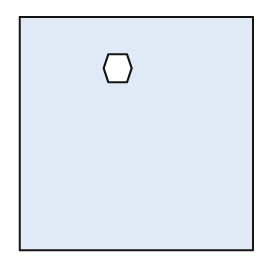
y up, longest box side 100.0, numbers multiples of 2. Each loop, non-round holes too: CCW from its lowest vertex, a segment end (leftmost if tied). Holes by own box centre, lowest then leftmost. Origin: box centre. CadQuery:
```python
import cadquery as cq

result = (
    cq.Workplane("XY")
    .moveTo(-50.0, -50.0)
    .lineTo(50.0, -50.0)
    .lineTo(50.0, 50.0)
    .lineTo(-50.0, 50.0)
    .close()
    .moveTo(-12.0, 22.0)
    .lineTo(-4.0, 22.0)
    .lineTo(-2.0, 28.0)
    .lineTo(-4.0, 34.0)
    .lineTo(-12.0, 34.0)
    .lineTo(-14.0, 28.0)
    .close()
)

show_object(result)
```